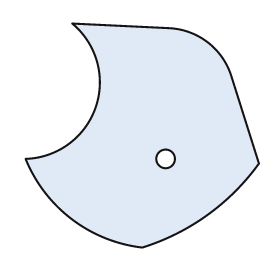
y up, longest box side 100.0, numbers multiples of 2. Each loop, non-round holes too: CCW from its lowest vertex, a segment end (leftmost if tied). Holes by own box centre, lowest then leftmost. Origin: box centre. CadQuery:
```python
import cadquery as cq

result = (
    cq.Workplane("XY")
    .moveTo(0.0, -48.0)
    .threePointArc((28.0, -34.0), (50.0, -12.0))
    .lineTo(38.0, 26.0)
    .threePointArc((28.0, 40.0), (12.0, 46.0))
    .lineTo(-30.0, 48.0)
    .threePointArc((-20.0, 12.0), (-50.0, -10.0))
    .threePointArc((-30.0, -36.0), (0.0, -48.0))
    .close()
    .moveTo(10.0, -10.0)
    .circle(4.0)
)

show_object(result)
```